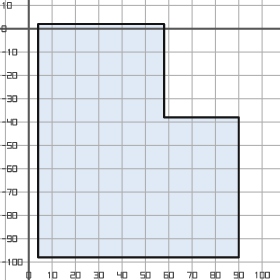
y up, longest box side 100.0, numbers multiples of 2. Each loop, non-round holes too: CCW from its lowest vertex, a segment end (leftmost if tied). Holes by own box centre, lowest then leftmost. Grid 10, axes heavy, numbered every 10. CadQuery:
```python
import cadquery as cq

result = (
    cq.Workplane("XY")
    .moveTo(4.0, -98.0)
    .lineTo(90.0, -98.0)
    .lineTo(90.0, -38.0)
    .lineTo(58.0, -38.0)
    .lineTo(58.0, 2.0)
    .lineTo(4.0, 2.0)
    .close()
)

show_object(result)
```